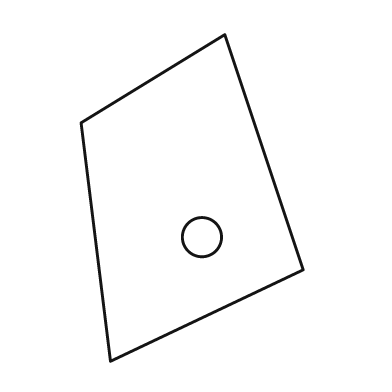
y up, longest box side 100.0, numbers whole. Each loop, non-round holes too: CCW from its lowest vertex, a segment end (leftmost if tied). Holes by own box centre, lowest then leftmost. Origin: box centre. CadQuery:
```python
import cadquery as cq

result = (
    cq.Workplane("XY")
    .moveTo(-25.0, -50.0)
    .lineTo(34.0, -22.0)
    .lineTo(10.0, 50.0)
    .lineTo(-34.0, 23.0)
    .close()
    .moveTo(3.0, -12.0)
    .circle(6.0)
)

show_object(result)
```